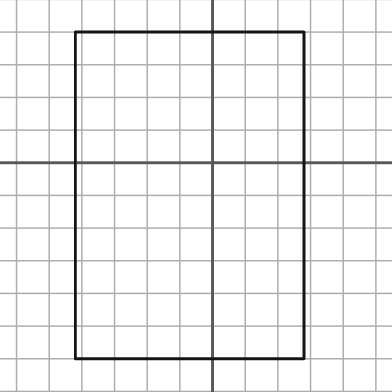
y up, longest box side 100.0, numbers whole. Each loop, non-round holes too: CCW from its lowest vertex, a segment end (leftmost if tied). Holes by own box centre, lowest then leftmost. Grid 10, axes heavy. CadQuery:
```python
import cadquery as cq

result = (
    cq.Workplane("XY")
    .moveTo(-42.0, -60.0)
    .lineTo(28.0, -60.0)
    .lineTo(28.0, 40.0)
    .lineTo(-42.0, 40.0)
    .close()
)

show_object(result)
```